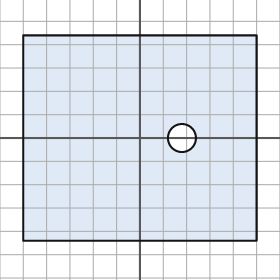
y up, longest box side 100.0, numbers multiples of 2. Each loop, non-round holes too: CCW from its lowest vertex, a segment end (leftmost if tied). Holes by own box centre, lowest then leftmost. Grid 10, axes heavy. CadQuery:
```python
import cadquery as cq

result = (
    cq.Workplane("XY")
    .moveTo(-50.0, -44.0)
    .lineTo(50.0, -44.0)
    .lineTo(50.0, 44.0)
    .lineTo(-50.0, 44.0)
    .close()
    .moveTo(18.0, 0.0)
    .circle(6.0)
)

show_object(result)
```